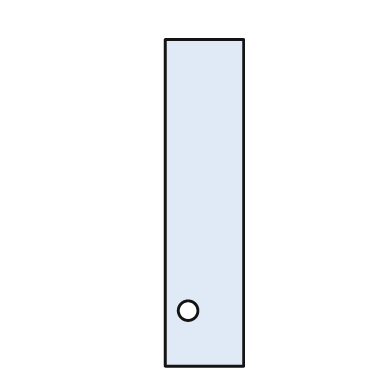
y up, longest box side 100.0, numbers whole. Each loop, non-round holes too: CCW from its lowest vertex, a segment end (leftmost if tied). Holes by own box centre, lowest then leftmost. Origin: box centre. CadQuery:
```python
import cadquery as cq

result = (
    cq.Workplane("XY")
    .moveTo(-12.0, -50.0)
    .lineTo(12.0, -50.0)
    .lineTo(12.0, 50.0)
    .lineTo(-12.0, 50.0)
    .close()
    .moveTo(-5.0, -33.0)
    .circle(3.0)
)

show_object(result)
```